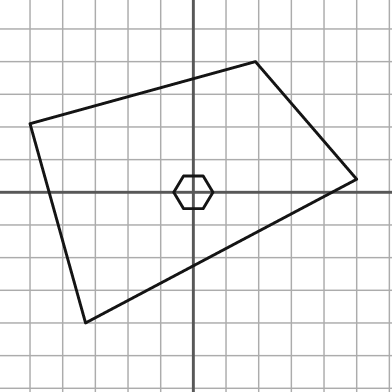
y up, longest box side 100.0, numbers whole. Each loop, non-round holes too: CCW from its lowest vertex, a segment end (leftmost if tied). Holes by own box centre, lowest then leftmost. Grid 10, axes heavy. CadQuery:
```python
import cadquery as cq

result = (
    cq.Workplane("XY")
    .moveTo(-33.0, -40.0)
    .lineTo(50.0, 4.0)
    .lineTo(19.0, 40.0)
    .lineTo(-50.0, 21.0)
    .close()
    .moveTo(-3.0, -5.0)
    .lineTo(3.0, -5.0)
    .lineTo(6.0, 0.0)
    .lineTo(3.0, 5.0)
    .lineTo(-3.0, 5.0)
    .lineTo(-6.0, 0.0)
    .close()
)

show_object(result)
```